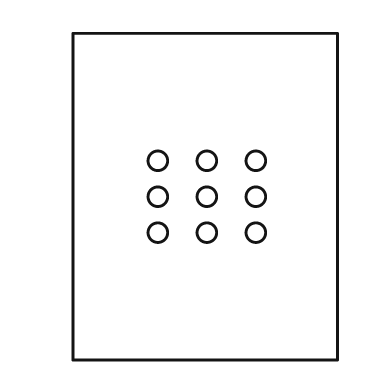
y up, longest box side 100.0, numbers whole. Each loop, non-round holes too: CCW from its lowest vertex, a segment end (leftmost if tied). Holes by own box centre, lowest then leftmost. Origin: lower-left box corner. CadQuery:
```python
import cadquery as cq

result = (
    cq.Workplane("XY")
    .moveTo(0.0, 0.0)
    .lineTo(81.0, 0.0)
    .lineTo(81.0, 100.0)
    .lineTo(0.0, 100.0)
    .close()
    .moveTo(26.0, 39.0)
    .circle(3.0)
    .moveTo(41.0, 39.0)
    .circle(3.0)
    .moveTo(56.0, 39.0)
    .circle(3.0)
    .moveTo(26.0, 50.0)
    .circle(3.0)
    .moveTo(41.0, 50.0)
    .circle(3.0)
    .moveTo(56.0, 50.0)
    .circle(3.0)
    .moveTo(26.0, 61.0)
    .circle(3.0)
    .moveTo(41.0, 61.0)
    .circle(3.0)
    .moveTo(56.0, 61.0)
    .circle(3.0)
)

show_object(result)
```